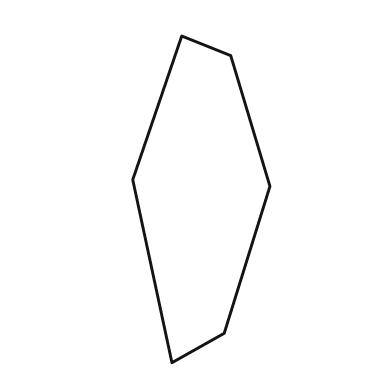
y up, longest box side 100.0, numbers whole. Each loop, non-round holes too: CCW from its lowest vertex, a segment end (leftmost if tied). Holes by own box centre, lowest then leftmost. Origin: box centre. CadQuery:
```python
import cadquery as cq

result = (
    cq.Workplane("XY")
    .moveTo(-9.0, -50.0)
    .lineTo(7.0, -41.0)
    .lineTo(21.0, 4.0)
    .lineTo(9.0, 44.0)
    .lineTo(-6.0, 50.0)
    .lineTo(-21.0, 6.0)
    .close()
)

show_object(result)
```